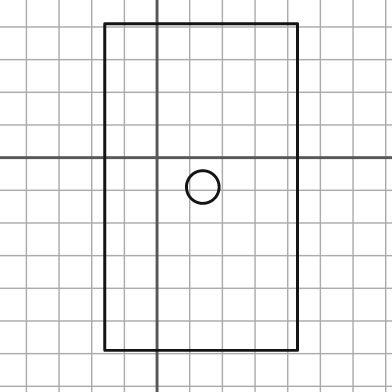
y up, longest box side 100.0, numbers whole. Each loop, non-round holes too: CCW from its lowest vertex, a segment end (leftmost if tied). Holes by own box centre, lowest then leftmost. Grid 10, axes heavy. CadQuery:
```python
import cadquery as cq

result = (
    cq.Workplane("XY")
    .moveTo(-16.0, -59.0)
    .lineTo(43.0, -59.0)
    .lineTo(43.0, 41.0)
    .lineTo(-16.0, 41.0)
    .close()
    .moveTo(14.0, -9.0)
    .circle(5.0)
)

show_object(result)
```